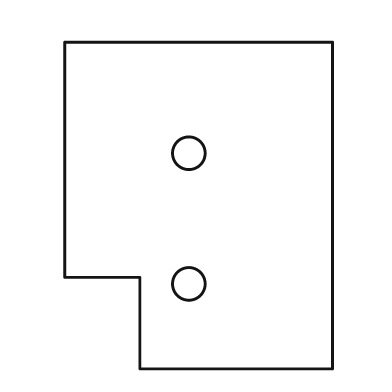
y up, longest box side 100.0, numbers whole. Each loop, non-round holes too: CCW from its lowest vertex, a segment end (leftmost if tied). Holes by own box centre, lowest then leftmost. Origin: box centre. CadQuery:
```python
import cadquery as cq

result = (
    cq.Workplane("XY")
    .moveTo(-18.0, -50.0)
    .lineTo(41.0, -50.0)
    .lineTo(41.0, 50.0)
    .lineTo(-41.0, 50.0)
    .lineTo(-41.0, -22.0)
    .lineTo(-18.0, -22.0)
    .close()
    .moveTo(-3.0, -24.0)
    .circle(5.0)
    .moveTo(-3.0, 16.0)
    .circle(5.0)
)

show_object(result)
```